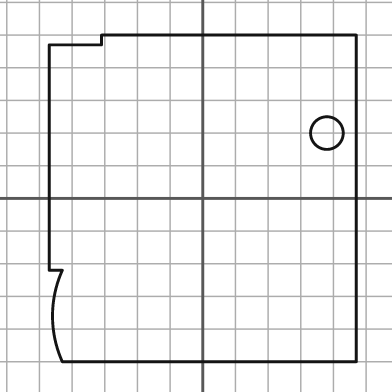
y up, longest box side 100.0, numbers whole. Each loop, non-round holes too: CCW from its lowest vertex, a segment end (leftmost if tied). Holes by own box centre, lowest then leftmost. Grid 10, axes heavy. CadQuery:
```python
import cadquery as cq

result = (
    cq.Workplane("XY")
    .moveTo(-43.0, -50.0)
    .lineTo(47.0, -50.0)
    .lineTo(47.0, 50.0)
    .lineTo(-31.0, 50.0)
    .lineTo(-31.0, 47.0)
    .lineTo(-47.0, 47.0)
    .lineTo(-47.0, -22.0)
    .lineTo(-43.0, -22.0)
    .threePointArc((-46.0, -36.0), (-43.0, -50.0))
    .close()
    .moveTo(38.0, 20.0)
    .circle(5.0)
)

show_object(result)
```